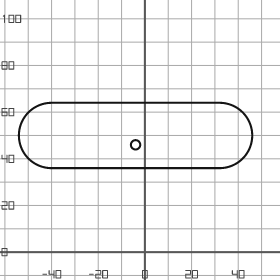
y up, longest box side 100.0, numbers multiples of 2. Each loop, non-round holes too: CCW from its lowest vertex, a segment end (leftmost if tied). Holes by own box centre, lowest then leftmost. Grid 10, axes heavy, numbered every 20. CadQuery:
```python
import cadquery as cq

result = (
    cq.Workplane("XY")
    .moveTo(-40.0, 36.0)
    .lineTo(32.0, 36.0)
    .threePointArc((46.0, 50.0), (32.0, 64.0))
    .lineTo(-40.0, 64.0)
    .threePointArc((-54.0, 50.0), (-40.0, 36.0))
    .close()
    .moveTo(-4.0, 46.0)
    .circle(2.0)
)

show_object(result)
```